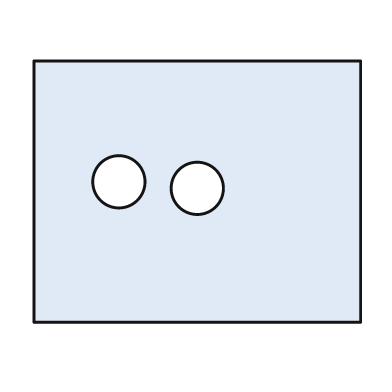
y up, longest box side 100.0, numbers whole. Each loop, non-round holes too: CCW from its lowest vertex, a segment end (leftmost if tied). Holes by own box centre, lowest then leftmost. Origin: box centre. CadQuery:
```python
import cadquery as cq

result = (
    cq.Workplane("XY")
    .moveTo(-50.0, -40.0)
    .lineTo(50.0, -40.0)
    .lineTo(50.0, 40.0)
    .lineTo(-50.0, 40.0)
    .close()
    .moveTo(0.0, 1.0)
    .circle(8.0)
    .moveTo(-24.0, 3.0)
    .circle(8.0)
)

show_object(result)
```